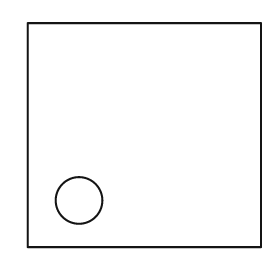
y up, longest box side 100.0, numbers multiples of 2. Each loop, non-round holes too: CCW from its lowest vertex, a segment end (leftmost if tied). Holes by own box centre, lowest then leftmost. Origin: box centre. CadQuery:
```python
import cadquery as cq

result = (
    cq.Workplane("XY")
    .moveTo(-50.0, -48.0)
    .lineTo(50.0, -48.0)
    .lineTo(50.0, 48.0)
    .lineTo(-50.0, 48.0)
    .close()
    .moveTo(-28.0, -28.0)
    .circle(10.0)
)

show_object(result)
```